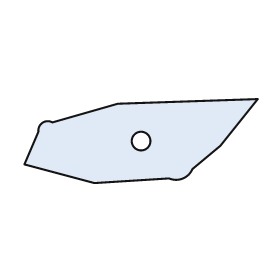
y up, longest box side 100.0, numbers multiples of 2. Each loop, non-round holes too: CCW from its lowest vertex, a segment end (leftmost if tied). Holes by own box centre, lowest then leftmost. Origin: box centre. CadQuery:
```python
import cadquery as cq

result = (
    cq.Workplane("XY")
    .moveTo(-20.0, -18.0)
    .lineTo(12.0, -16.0)
    .threePointArc((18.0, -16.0), (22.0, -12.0))
    .lineTo(34.0, -2.0)
    .lineTo(50.0, 18.0)
    .lineTo(-10.0, 16.0)
    .lineTo(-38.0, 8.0)
    .threePointArc((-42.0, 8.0), (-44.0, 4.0))
    .lineTo(-50.0, -10.0)
    .close()
    .moveTo(0.0, 0.0)
    .circle(4.0)
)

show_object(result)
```